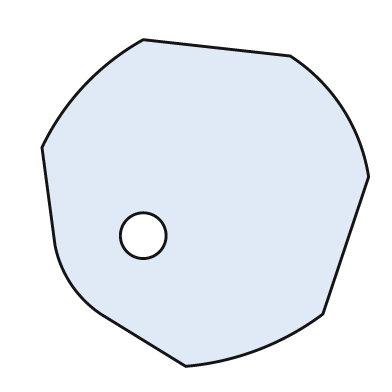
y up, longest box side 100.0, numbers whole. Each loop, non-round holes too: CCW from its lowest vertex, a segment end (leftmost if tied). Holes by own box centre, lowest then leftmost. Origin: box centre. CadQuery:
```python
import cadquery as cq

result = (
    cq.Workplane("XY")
    .moveTo(-6.0, -50.0)
    .threePointArc((16.0, -45.0), (36.0, -34.0))
    .lineTo(50.0, 8.0)
    .threePointArc((42.0, 29.0), (26.0, 45.0))
    .lineTo(-19.0, 50.0)
    .threePointArc((-37.0, 36.0), (-50.0, 17.0))
    .lineTo(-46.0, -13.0)
    .threePointArc((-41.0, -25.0), (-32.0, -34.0))
    .close()
    .moveTo(-19.0, -10.0)
    .circle(7.0)
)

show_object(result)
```